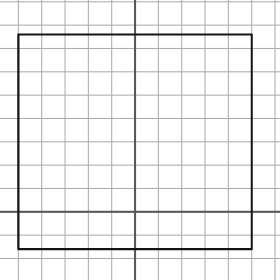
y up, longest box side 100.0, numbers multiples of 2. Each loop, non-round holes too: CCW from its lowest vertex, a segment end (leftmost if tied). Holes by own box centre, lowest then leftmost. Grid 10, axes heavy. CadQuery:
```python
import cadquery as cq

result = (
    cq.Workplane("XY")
    .moveTo(-50.0, -16.0)
    .lineTo(50.0, -16.0)
    .lineTo(50.0, 76.0)
    .lineTo(-50.0, 76.0)
    .close()
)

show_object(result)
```